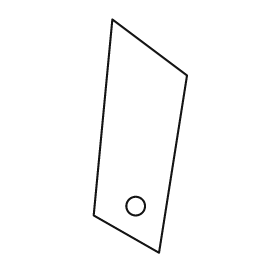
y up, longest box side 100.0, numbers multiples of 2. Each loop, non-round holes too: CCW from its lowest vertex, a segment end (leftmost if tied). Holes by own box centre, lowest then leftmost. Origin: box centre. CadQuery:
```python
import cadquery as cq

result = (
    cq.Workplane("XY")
    .moveTo(8.0, -50.0)
    .lineTo(20.0, 26.0)
    .lineTo(-12.0, 50.0)
    .lineTo(-20.0, -34.0)
    .close()
    .moveTo(-2.0, -30.0)
    .circle(4.0)
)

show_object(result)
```